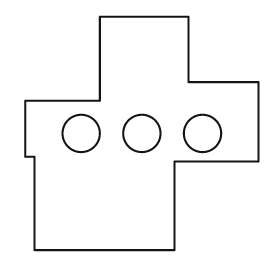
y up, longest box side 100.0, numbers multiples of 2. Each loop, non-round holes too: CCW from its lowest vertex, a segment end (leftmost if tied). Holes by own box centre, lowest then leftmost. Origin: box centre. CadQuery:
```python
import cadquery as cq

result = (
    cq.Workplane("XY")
    .moveTo(-46.0, -50.0)
    .lineTo(14.0, -50.0)
    .lineTo(14.0, -12.0)
    .lineTo(50.0, -12.0)
    .lineTo(50.0, 22.0)
    .lineTo(20.0, 22.0)
    .lineTo(20.0, 50.0)
    .lineTo(-18.0, 50.0)
    .lineTo(-18.0, 14.0)
    .lineTo(-50.0, 14.0)
    .lineTo(-50.0, -10.0)
    .lineTo(-46.0, -10.0)
    .close()
    .moveTo(-26.0, 0.0)
    .circle(8.0)
    .moveTo(0.0, 0.0)
    .circle(8.0)
    .moveTo(26.0, 0.0)
    .circle(8.0)
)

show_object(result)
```